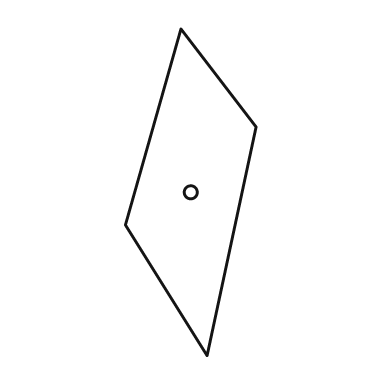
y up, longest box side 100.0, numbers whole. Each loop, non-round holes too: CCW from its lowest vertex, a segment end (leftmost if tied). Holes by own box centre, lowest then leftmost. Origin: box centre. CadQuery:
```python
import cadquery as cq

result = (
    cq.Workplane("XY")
    .moveTo(5.0, -50.0)
    .lineTo(20.0, 20.0)
    .lineTo(-3.0, 50.0)
    .lineTo(-20.0, -10.0)
    .close()
    .moveTo(0.0, 0.0)
    .circle(2.0)
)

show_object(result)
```